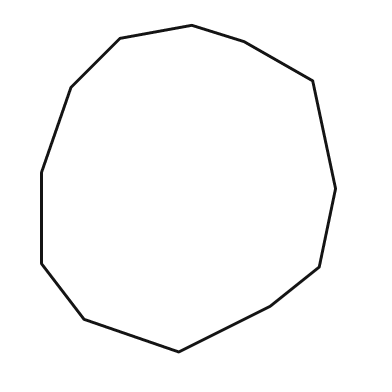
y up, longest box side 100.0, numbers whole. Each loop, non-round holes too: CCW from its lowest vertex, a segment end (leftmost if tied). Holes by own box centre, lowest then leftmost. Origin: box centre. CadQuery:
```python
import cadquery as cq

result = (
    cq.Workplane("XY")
    .moveTo(-3.0, -50.0)
    .lineTo(25.0, -36.0)
    .lineTo(40.0, -24.0)
    .lineTo(45.0, 0.0)
    .lineTo(38.0, 33.0)
    .lineTo(17.0, 45.0)
    .lineTo(1.0, 50.0)
    .lineTo(-21.0, 46.0)
    .lineTo(-36.0, 31.0)
    .lineTo(-45.0, 5.0)
    .lineTo(-45.0, -23.0)
    .lineTo(-32.0, -40.0)
    .close()
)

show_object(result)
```